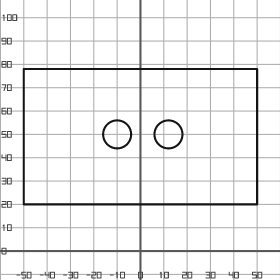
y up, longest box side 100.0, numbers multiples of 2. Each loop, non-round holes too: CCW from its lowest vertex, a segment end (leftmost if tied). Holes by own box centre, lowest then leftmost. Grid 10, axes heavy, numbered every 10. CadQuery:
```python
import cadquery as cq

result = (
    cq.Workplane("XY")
    .moveTo(-50.0, 20.0)
    .lineTo(50.0, 20.0)
    .lineTo(50.0, 78.0)
    .lineTo(-50.0, 78.0)
    .close()
    .moveTo(-10.0, 50.0)
    .circle(6.0)
    .moveTo(12.0, 50.0)
    .circle(6.0)
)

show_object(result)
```